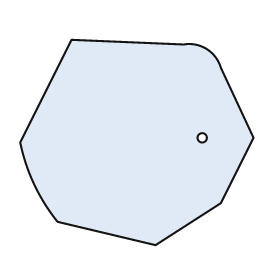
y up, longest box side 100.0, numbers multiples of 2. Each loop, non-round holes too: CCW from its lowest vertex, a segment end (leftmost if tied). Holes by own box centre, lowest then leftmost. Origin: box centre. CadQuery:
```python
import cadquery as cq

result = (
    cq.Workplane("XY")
    .moveTo(8.0, -44.0)
    .lineTo(36.0, -26.0)
    .lineTo(50.0, 2.0)
    .lineTo(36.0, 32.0)
    .threePointArc((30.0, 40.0), (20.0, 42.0))
    .lineTo(-28.0, 44.0)
    .lineTo(-50.0, 0.0)
    .threePointArc((-44.0, -18.0), (-34.0, -34.0))
    .close()
    .moveTo(28.0, 2.0)
    .circle(2.0)
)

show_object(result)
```